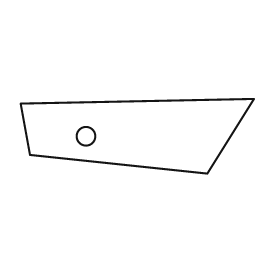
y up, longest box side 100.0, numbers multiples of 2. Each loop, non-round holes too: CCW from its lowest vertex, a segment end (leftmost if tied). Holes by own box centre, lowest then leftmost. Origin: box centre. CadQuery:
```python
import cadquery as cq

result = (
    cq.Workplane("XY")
    .moveTo(30.0, -16.0)
    .lineTo(50.0, 16.0)
    .lineTo(-50.0, 14.0)
    .lineTo(-46.0, -8.0)
    .close()
    .moveTo(-22.0, 0.0)
    .circle(4.0)
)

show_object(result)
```